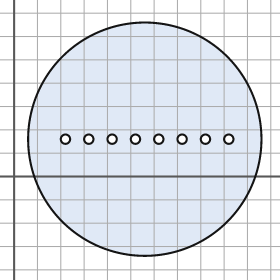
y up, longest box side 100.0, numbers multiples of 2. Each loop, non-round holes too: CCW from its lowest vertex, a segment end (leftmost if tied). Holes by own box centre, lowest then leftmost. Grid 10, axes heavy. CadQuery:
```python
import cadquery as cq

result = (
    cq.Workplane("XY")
    .moveTo(56.0, 16.0)
    .circle(50.0)
    .moveTo(22.0, 16.0)
    .circle(2.0)
    .moveTo(32.0, 16.0)
    .circle(2.0)
    .moveTo(42.0, 16.0)
    .circle(2.0)
    .moveTo(52.0, 16.0)
    .circle(2.0)
    .moveTo(62.0, 16.0)
    .circle(2.0)
    .moveTo(72.0, 16.0)
    .circle(2.0)
    .moveTo(82.0, 16.0)
    .circle(2.0)
    .moveTo(92.0, 16.0)
    .circle(2.0)
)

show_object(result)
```